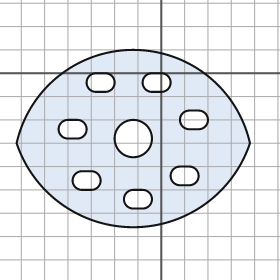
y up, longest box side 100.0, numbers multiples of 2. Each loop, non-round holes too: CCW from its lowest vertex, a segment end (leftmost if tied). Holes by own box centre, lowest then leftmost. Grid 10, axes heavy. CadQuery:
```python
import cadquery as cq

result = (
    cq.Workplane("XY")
    .moveTo(-62.0, -30.0)
    .threePointArc((-12.0, -66.0), (38.0, -30.0))
    .threePointArc((-12.0, 10.0), (-62.0, -30.0))
    .close()
    .moveTo(-12.0, -58.0)
    .lineTo(-8.0, -58.0)
    .threePointArc((-4.0, -54.0), (-8.0, -50.0))
    .lineTo(-12.0, -50.0)
    .threePointArc((-16.0, -54.0), (-12.0, -58.0))
    .close()
    .moveTo(-34.0, -50.0)
    .lineTo(-30.0, -50.0)
    .threePointArc((-26.0, -46.0), (-30.0, -42.0))
    .lineTo(-34.0, -42.0)
    .threePointArc((-38.0, -46.0), (-34.0, -50.0))
    .close()
    .moveTo(8.0, -48.0)
    .lineTo(12.0, -48.0)
    .threePointArc((16.0, -44.0), (12.0, -40.0))
    .lineTo(8.0, -40.0)
    .threePointArc((4.0, -44.0), (8.0, -48.0))
    .close()
    .moveTo(-12.0, -28.0)
    .circle(8.0)
    .moveTo(-40.0, -28.0)
    .lineTo(-36.0, -28.0)
    .threePointArc((-32.0, -24.0), (-36.0, -20.0))
    .lineTo(-40.0, -20.0)
    .threePointArc((-44.0, -24.0), (-40.0, -28.0))
    .close()
    .moveTo(12.0, -24.0)
    .lineTo(16.0, -24.0)
    .threePointArc((20.0, -20.0), (16.0, -16.0))
    .lineTo(12.0, -16.0)
    .threePointArc((8.0, -20.0), (12.0, -24.0))
    .close()
    .moveTo(-28.0, -8.0)
    .lineTo(-24.0, -8.0)
    .threePointArc((-20.0, -4.0), (-24.0, 0.0))
    .lineTo(-28.0, 0.0)
    .threePointArc((-32.0, -4.0), (-28.0, -8.0))
    .close()
    .moveTo(-4.0, -8.0)
    .lineTo(0.0, -8.0)
    .threePointArc((4.0, -4.0), (0.0, 0.0))
    .lineTo(-4.0, 0.0)
    .threePointArc((-8.0, -4.0), (-4.0, -8.0))
    .close()
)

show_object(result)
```